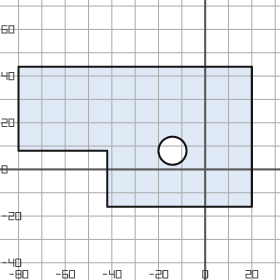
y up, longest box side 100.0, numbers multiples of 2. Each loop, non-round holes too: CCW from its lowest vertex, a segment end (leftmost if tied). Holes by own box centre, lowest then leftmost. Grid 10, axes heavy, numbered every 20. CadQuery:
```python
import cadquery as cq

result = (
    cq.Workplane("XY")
    .moveTo(-42.0, -16.0)
    .lineTo(20.0, -16.0)
    .lineTo(20.0, 44.0)
    .lineTo(-80.0, 44.0)
    .lineTo(-80.0, 8.0)
    .lineTo(-42.0, 8.0)
    .close()
    .moveTo(-14.0, 8.0)
    .circle(6.0)
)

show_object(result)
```